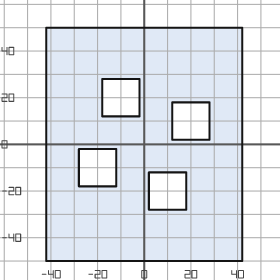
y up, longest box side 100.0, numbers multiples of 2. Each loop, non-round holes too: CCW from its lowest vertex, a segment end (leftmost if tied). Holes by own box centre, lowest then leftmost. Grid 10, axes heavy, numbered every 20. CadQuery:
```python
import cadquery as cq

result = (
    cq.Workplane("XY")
    .moveTo(-42.0, -50.0)
    .lineTo(42.0, -50.0)
    .lineTo(42.0, 50.0)
    .lineTo(-42.0, 50.0)
    .close()
    .moveTo(2.0, -28.0)
    .lineTo(18.0, -28.0)
    .lineTo(18.0, -12.0)
    .lineTo(2.0, -12.0)
    .close()
    .moveTo(-28.0, -18.0)
    .lineTo(-12.0, -18.0)
    .lineTo(-12.0, -2.0)
    .lineTo(-28.0, -2.0)
    .close()
    .moveTo(12.0, 2.0)
    .lineTo(28.0, 2.0)
    .lineTo(28.0, 18.0)
    .lineTo(12.0, 18.0)
    .close()
    .moveTo(-18.0, 12.0)
    .lineTo(-2.0, 12.0)
    .lineTo(-2.0, 28.0)
    .lineTo(-18.0, 28.0)
    .close()
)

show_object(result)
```